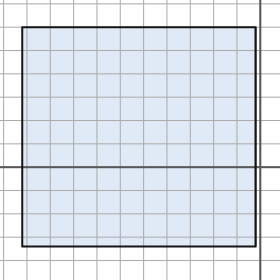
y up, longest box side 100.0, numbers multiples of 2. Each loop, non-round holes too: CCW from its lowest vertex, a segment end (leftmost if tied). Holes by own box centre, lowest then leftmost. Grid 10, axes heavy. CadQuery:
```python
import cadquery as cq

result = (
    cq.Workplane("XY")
    .moveTo(-102.0, -34.0)
    .lineTo(-2.0, -34.0)
    .lineTo(-2.0, 60.0)
    .lineTo(-102.0, 60.0)
    .close()
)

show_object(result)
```